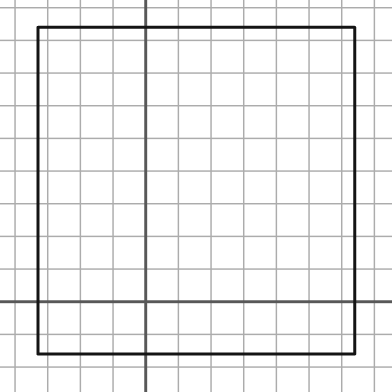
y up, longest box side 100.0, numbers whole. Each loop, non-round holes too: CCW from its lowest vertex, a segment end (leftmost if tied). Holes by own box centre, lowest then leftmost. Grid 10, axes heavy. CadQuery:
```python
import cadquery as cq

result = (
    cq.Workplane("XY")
    .moveTo(-33.0, -16.0)
    .lineTo(64.0, -16.0)
    .lineTo(64.0, 84.0)
    .lineTo(-33.0, 84.0)
    .close()
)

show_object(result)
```